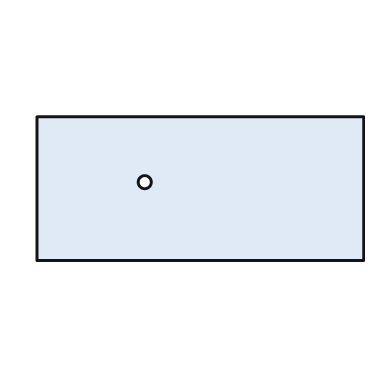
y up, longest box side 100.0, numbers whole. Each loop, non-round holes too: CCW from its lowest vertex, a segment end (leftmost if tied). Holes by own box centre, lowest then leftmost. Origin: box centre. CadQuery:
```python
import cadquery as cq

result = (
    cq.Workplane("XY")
    .moveTo(-50.0, -22.0)
    .lineTo(50.0, -22.0)
    .lineTo(50.0, 22.0)
    .lineTo(-50.0, 22.0)
    .close()
    .moveTo(-17.0, 2.0)
    .circle(2.0)
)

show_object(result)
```